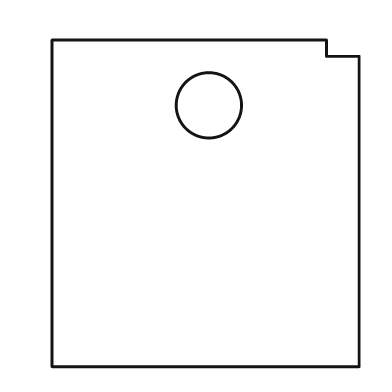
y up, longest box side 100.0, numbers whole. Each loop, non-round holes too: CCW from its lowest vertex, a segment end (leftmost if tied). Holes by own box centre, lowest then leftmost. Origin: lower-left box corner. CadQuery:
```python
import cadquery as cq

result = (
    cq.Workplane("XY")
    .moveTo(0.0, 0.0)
    .lineTo(94.0, 0.0)
    .lineTo(94.0, 95.0)
    .lineTo(84.0, 95.0)
    .lineTo(84.0, 100.0)
    .lineTo(0.0, 100.0)
    .close()
    .moveTo(48.0, 80.0)
    .circle(10.0)
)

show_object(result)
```